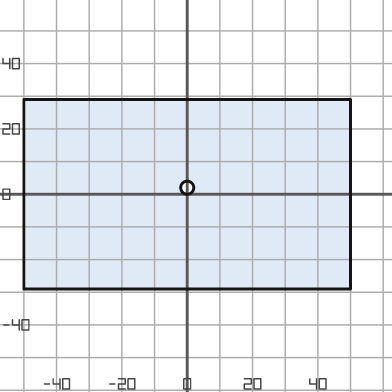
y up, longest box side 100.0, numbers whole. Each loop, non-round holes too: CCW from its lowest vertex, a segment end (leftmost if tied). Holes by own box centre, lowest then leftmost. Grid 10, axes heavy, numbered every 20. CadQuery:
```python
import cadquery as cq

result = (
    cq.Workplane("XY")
    .moveTo(-50.0, -29.0)
    .lineTo(50.0, -29.0)
    .lineTo(50.0, 29.0)
    .lineTo(-50.0, 29.0)
    .close()
    .moveTo(0.0, 2.0)
    .circle(2.0)
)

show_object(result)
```